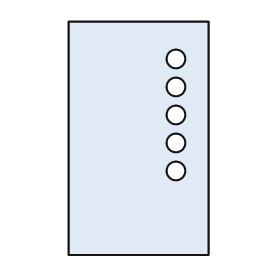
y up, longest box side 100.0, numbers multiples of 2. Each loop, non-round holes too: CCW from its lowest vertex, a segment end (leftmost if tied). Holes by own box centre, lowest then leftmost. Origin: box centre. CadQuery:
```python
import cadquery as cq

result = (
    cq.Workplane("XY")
    .moveTo(-30.0, -50.0)
    .lineTo(30.0, -50.0)
    .lineTo(30.0, 50.0)
    .lineTo(-30.0, 50.0)
    .close()
    .moveTo(16.0, -14.0)
    .circle(4.0)
    .moveTo(16.0, -2.0)
    .circle(4.0)
    .moveTo(16.0, 10.0)
    .circle(4.0)
    .moveTo(16.0, 22.0)
    .circle(4.0)
    .moveTo(16.0, 34.0)
    .circle(4.0)
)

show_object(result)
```